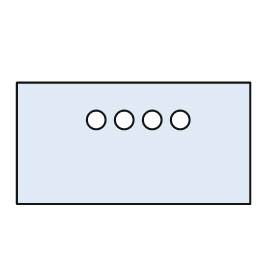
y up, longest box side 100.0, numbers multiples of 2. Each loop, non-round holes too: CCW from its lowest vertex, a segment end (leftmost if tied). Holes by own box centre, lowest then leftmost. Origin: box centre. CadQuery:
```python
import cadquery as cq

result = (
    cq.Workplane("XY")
    .moveTo(-50.0, -26.0)
    .lineTo(50.0, -26.0)
    .lineTo(50.0, 26.0)
    .lineTo(-50.0, 26.0)
    .close()
    .moveTo(-16.0, 10.0)
    .circle(4.0)
    .moveTo(-4.0, 10.0)
    .circle(4.0)
    .moveTo(8.0, 10.0)
    .circle(4.0)
    .moveTo(20.0, 10.0)
    .circle(4.0)
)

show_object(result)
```